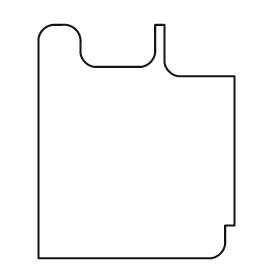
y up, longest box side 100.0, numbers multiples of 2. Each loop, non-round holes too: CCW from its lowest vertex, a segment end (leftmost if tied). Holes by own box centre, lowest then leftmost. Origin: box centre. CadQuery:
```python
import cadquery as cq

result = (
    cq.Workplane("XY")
    .moveTo(-42.0, -50.0)
    .lineTo(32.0, -50.0)
    .threePointArc((36.0, -48.0), (38.0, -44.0))
    .lineTo(38.0, -36.0)
    .lineTo(42.0, -36.0)
    .lineTo(42.0, 28.0)
    .lineTo(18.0, 28.0)
    .threePointArc((14.0, 30.0), (12.0, 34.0))
    .lineTo(12.0, 50.0)
    .lineTo(8.0, 50.0)
    .lineTo(8.0, 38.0)
    .threePointArc((6.0, 34.0), (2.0, 32.0))
    .lineTo(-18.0, 32.0)
    .threePointArc((-22.0, 34.0), (-24.0, 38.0))
    .lineTo(-24.0, 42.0)
    .threePointArc((-26.0, 48.0), (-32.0, 50.0))
    .lineTo(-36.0, 50.0)
    .threePointArc((-40.0, 48.0), (-42.0, 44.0))
    .close()
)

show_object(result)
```